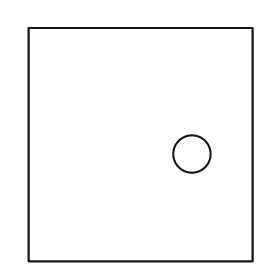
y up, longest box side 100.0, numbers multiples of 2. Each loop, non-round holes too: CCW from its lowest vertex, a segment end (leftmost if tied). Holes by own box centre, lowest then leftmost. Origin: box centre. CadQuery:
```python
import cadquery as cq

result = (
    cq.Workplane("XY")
    .moveTo(-48.0, -50.0)
    .lineTo(48.0, -50.0)
    .lineTo(48.0, 50.0)
    .lineTo(-48.0, 50.0)
    .close()
    .moveTo(22.0, -4.0)
    .circle(8.0)
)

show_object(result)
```